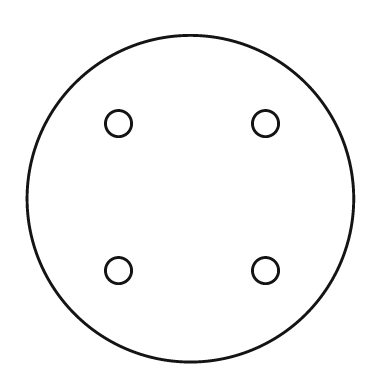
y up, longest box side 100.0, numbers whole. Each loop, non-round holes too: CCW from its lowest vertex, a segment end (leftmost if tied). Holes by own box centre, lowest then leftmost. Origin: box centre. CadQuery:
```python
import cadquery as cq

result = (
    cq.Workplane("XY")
    .moveTo(0.0, 0.0)
    .circle(50.0)
    .moveTo(-22.0, -22.0)
    .circle(4.0)
    .moveTo(23.0, -22.0)
    .circle(4.0)
    .moveTo(-22.0, 23.0)
    .circle(4.0)
    .moveTo(23.0, 23.0)
    .circle(4.0)
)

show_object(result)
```